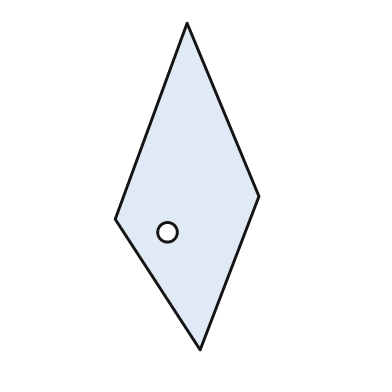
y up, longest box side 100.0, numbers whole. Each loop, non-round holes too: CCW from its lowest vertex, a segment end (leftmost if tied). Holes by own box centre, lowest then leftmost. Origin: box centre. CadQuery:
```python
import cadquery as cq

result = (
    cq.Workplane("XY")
    .moveTo(4.0, -50.0)
    .lineTo(22.0, -3.0)
    .lineTo(0.0, 50.0)
    .lineTo(-22.0, -10.0)
    .close()
    .moveTo(-6.0, -14.0)
    .circle(3.0)
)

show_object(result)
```